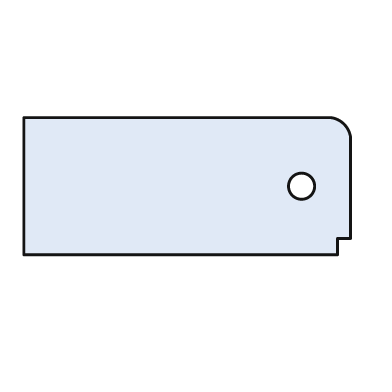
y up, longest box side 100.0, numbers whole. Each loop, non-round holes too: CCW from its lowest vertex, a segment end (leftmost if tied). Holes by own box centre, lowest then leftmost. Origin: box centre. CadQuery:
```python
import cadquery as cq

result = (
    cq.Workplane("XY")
    .moveTo(-50.0, -21.0)
    .lineTo(46.0, -21.0)
    .lineTo(46.0, -16.0)
    .lineTo(50.0, -16.0)
    .lineTo(50.0, 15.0)
    .threePointArc((48.0, 19.0), (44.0, 21.0))
    .lineTo(-50.0, 21.0)
    .close()
    .moveTo(35.0, 0.0)
    .circle(4.0)
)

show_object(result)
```